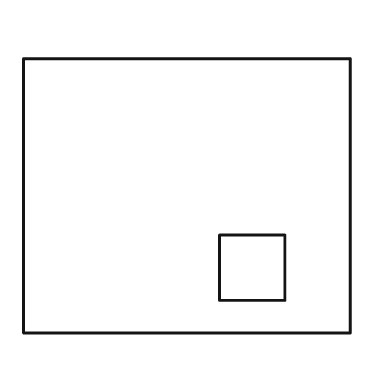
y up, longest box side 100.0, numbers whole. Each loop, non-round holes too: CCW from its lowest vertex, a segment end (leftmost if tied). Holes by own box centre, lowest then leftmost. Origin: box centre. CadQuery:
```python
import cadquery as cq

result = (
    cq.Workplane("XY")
    .moveTo(-50.0, -42.0)
    .lineTo(50.0, -42.0)
    .lineTo(50.0, 42.0)
    .lineTo(-50.0, 42.0)
    .close()
    .moveTo(10.0, -32.0)
    .lineTo(30.0, -32.0)
    .lineTo(30.0, -12.0)
    .lineTo(10.0, -12.0)
    .close()
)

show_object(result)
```